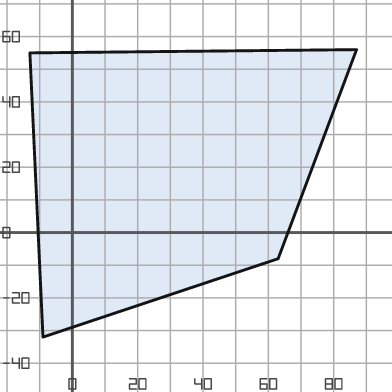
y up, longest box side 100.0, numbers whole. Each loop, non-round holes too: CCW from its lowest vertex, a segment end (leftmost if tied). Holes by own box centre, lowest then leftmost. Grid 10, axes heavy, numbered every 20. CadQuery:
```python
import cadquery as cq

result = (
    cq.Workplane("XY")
    .moveTo(-9.0, -32.0)
    .lineTo(63.0, -8.0)
    .lineTo(87.0, 56.0)
    .lineTo(-13.0, 55.0)
    .close()
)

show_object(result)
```